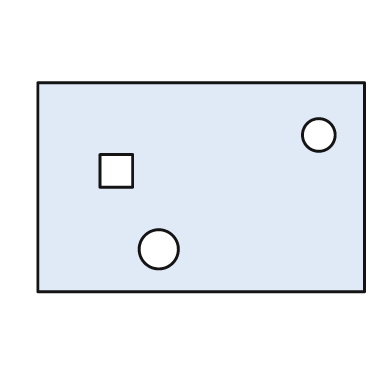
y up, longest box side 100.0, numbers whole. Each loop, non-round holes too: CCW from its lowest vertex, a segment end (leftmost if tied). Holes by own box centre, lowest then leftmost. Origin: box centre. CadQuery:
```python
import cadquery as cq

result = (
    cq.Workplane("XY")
    .moveTo(-50.0, -32.0)
    .lineTo(50.0, -32.0)
    .lineTo(50.0, 32.0)
    .lineTo(-50.0, 32.0)
    .close()
    .moveTo(-13.0, -19.0)
    .circle(6.0)
    .moveTo(-31.0, 0.0)
    .lineTo(-21.0, 0.0)
    .lineTo(-21.0, 10.0)
    .lineTo(-31.0, 10.0)
    .close()
    .moveTo(36.0, 16.0)
    .circle(5.0)
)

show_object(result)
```